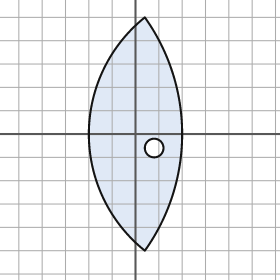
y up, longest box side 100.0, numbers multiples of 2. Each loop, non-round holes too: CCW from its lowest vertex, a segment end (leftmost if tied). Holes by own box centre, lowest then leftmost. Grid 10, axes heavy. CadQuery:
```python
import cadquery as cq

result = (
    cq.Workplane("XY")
    .moveTo(4.0, -50.0)
    .threePointArc((20.0, 0.0), (4.0, 50.0))
    .threePointArc((-20.0, 0.0), (4.0, -50.0))
    .close()
    .moveTo(8.0, -6.0)
    .circle(4.0)
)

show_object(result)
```